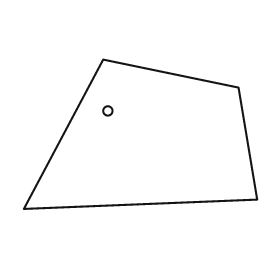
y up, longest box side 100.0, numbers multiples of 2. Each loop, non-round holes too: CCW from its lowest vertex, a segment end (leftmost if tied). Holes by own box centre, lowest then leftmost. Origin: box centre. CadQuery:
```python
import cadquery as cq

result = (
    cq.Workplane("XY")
    .moveTo(-50.0, -32.0)
    .lineTo(50.0, -28.0)
    .lineTo(42.0, 20.0)
    .lineTo(-16.0, 32.0)
    .close()
    .moveTo(-14.0, 10.0)
    .circle(2.0)
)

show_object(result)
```